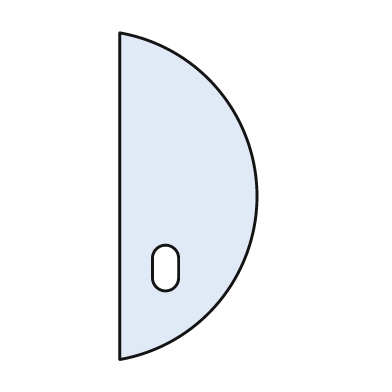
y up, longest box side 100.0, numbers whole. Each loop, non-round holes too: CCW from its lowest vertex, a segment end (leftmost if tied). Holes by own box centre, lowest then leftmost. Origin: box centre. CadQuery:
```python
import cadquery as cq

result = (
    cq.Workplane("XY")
    .moveTo(-21.0, -50.0)
    .threePointArc((21.0, 0.0), (-21.0, 50.0))
    .close()
    .moveTo(-11.0, -25.0)
    .threePointArc((-7.0, -29.0), (-3.0, -25.0))
    .lineTo(-3.0, -19.0)
    .threePointArc((-7.0, -15.0), (-11.0, -19.0))
    .close()
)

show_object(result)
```